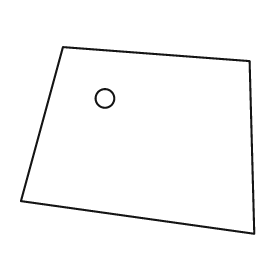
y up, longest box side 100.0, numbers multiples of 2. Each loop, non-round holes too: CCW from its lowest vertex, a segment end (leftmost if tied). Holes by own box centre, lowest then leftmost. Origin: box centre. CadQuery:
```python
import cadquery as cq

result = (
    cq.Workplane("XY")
    .moveTo(50.0, -40.0)
    .lineTo(48.0, 34.0)
    .lineTo(-32.0, 40.0)
    .lineTo(-50.0, -26.0)
    .close()
    .moveTo(-14.0, 18.0)
    .circle(4.0)
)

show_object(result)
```